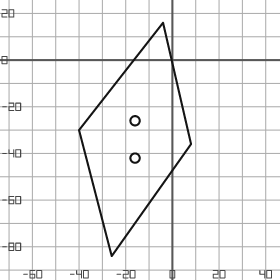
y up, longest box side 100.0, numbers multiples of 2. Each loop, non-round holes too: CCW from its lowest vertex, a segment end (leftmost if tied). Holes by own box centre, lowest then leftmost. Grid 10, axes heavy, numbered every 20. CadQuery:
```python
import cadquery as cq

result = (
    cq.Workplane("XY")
    .moveTo(-26.0, -84.0)
    .lineTo(8.0, -36.0)
    .lineTo(-4.0, 16.0)
    .lineTo(-40.0, -30.0)
    .close()
    .moveTo(-16.0, -42.0)
    .circle(2.0)
    .moveTo(-16.0, -26.0)
    .circle(2.0)
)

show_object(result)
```